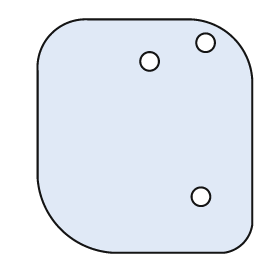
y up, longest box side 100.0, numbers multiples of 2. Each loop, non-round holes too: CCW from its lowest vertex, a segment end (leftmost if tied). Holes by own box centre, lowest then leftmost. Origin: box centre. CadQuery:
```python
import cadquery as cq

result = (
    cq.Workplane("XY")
    .moveTo(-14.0, -50.0)
    .lineTo(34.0, -50.0)
    .threePointArc((42.0, -46.0), (46.0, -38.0))
    .lineTo(46.0, 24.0)
    .threePointArc((38.0, 42.0), (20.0, 50.0))
    .lineTo(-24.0, 50.0)
    .threePointArc((-40.0, 44.0), (-46.0, 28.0))
    .lineTo(-46.0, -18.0)
    .threePointArc((-36.0, -40.0), (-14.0, -50.0))
    .close()
    .moveTo(24.0, -26.0)
    .circle(4.0)
    .moveTo(2.0, 32.0)
    .circle(4.0)
    .moveTo(26.0, 40.0)
    .circle(4.0)
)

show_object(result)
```